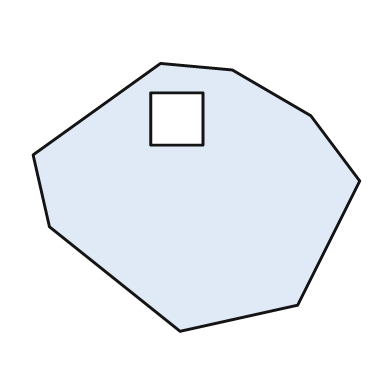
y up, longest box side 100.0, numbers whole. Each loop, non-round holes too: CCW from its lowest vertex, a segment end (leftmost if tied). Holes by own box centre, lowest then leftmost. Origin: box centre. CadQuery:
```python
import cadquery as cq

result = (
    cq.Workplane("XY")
    .moveTo(-5.0, -41.0)
    .lineTo(31.0, -33.0)
    .lineTo(50.0, 5.0)
    .lineTo(35.0, 25.0)
    .lineTo(11.0, 39.0)
    .lineTo(-11.0, 41.0)
    .lineTo(-50.0, 13.0)
    .lineTo(-45.0, -9.0)
    .close()
    .moveTo(-14.0, 16.0)
    .lineTo(2.0, 16.0)
    .lineTo(2.0, 32.0)
    .lineTo(-14.0, 32.0)
    .close()
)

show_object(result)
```